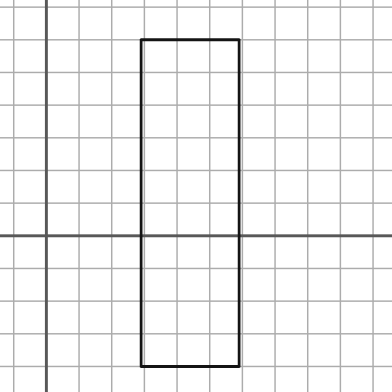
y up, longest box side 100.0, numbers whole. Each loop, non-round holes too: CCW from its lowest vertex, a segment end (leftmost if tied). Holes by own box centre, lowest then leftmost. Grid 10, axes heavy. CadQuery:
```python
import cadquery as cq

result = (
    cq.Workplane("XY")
    .moveTo(29.0, -40.0)
    .lineTo(59.0, -40.0)
    .lineTo(59.0, 60.0)
    .lineTo(29.0, 60.0)
    .close()
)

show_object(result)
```